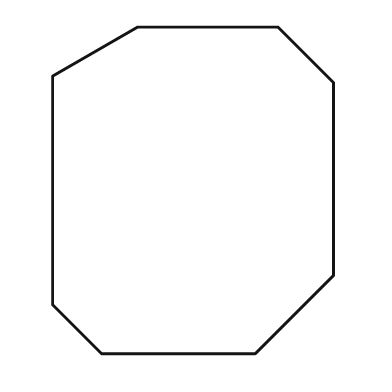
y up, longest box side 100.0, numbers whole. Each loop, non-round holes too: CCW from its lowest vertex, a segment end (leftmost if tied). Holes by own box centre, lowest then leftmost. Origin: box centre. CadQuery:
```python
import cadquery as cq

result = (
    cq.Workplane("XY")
    .moveTo(-28.0, -50.0)
    .lineTo(19.0, -50.0)
    .lineTo(43.0, -26.0)
    .lineTo(43.0, 33.0)
    .lineTo(26.0, 50.0)
    .lineTo(-17.0, 50.0)
    .lineTo(-43.0, 35.0)
    .lineTo(-43.0, -35.0)
    .close()
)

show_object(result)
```